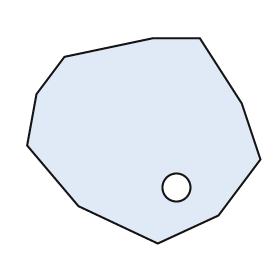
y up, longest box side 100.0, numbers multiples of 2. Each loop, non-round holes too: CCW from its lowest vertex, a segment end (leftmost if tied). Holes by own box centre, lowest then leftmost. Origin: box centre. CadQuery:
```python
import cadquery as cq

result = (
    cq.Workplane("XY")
    .moveTo(6.0, -44.0)
    .lineTo(32.0, -32.0)
    .lineTo(50.0, -8.0)
    .lineTo(42.0, 16.0)
    .lineTo(24.0, 44.0)
    .lineTo(4.0, 44.0)
    .lineTo(-34.0, 36.0)
    .lineTo(-46.0, 20.0)
    .lineTo(-50.0, -2.0)
    .lineTo(-28.0, -28.0)
    .close()
    .moveTo(14.0, -20.0)
    .circle(6.0)
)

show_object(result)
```